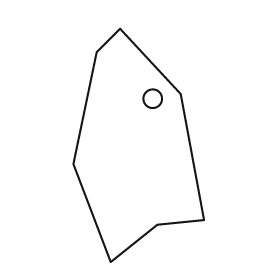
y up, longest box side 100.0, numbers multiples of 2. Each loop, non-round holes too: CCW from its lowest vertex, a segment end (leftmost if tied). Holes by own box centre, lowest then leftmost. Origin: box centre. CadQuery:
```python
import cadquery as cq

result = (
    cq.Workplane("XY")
    .moveTo(-12.0, -50.0)
    .lineTo(8.0, -34.0)
    .lineTo(28.0, -32.0)
    .lineTo(18.0, 22.0)
    .lineTo(-8.0, 50.0)
    .lineTo(-18.0, 40.0)
    .lineTo(-28.0, -8.0)
    .close()
    .moveTo(6.0, 20.0)
    .circle(4.0)
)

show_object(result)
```